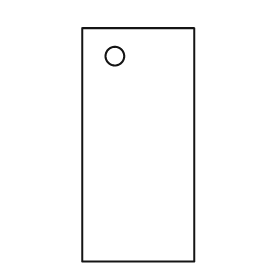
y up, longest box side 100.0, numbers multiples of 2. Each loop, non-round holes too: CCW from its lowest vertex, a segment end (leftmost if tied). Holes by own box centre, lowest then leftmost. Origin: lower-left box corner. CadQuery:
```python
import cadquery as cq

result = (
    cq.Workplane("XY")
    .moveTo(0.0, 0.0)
    .lineTo(48.0, 0.0)
    .lineTo(48.0, 100.0)
    .lineTo(0.0, 100.0)
    .close()
    .moveTo(14.0, 88.0)
    .circle(4.0)
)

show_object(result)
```